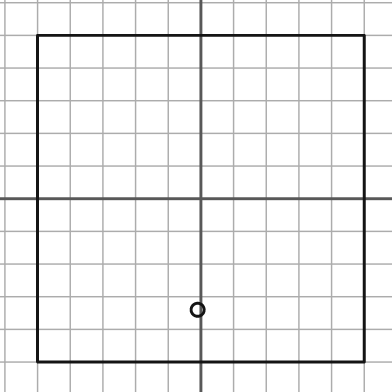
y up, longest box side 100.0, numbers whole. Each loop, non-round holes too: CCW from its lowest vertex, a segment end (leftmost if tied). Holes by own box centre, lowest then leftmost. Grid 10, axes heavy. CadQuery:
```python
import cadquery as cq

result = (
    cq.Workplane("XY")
    .moveTo(-50.0, -50.0)
    .lineTo(50.0, -50.0)
    .lineTo(50.0, 50.0)
    .lineTo(-50.0, 50.0)
    .close()
    .moveTo(-1.0, -34.0)
    .circle(2.0)
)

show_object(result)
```